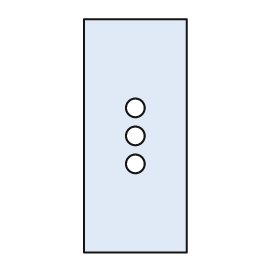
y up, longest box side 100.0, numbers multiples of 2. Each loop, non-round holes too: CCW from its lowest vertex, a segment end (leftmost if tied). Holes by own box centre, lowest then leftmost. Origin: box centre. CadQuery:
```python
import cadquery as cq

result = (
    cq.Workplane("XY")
    .moveTo(-22.0, -50.0)
    .lineTo(22.0, -50.0)
    .lineTo(22.0, 50.0)
    .lineTo(-22.0, 50.0)
    .close()
    .moveTo(0.0, -12.0)
    .circle(4.0)
    .moveTo(0.0, 0.0)
    .circle(4.0)
    .moveTo(0.0, 12.0)
    .circle(4.0)
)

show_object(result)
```